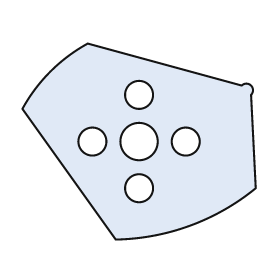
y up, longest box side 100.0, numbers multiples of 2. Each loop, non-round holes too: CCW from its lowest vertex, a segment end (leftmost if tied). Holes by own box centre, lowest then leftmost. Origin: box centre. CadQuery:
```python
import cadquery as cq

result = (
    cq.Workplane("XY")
    .moveTo(-10.0, -42.0)
    .threePointArc((22.0, -36.0), (50.0, -20.0))
    .lineTo(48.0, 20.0)
    .threePointArc((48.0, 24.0), (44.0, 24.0))
    .lineTo(-22.0, 42.0)
    .threePointArc((-38.0, 30.0), (-50.0, 14.0))
    .close()
    .moveTo(0.0, -20.0)
    .circle(6.0)
    .moveTo(-20.0, 0.0)
    .circle(6.0)
    .moveTo(0.0, 0.0)
    .circle(8.0)
    .moveTo(20.0, 0.0)
    .circle(6.0)
    .moveTo(0.0, 20.0)
    .circle(6.0)
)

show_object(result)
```